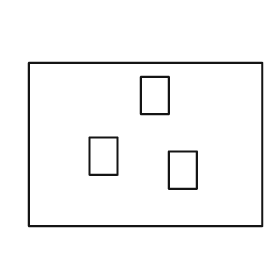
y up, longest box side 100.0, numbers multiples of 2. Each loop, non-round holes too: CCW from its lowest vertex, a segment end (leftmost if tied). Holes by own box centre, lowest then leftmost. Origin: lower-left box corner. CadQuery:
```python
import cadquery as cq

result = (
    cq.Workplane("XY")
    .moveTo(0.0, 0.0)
    .lineTo(100.0, 0.0)
    .lineTo(100.0, 70.0)
    .lineTo(0.0, 70.0)
    .close()
    .moveTo(60.0, 16.0)
    .lineTo(72.0, 16.0)
    .lineTo(72.0, 32.0)
    .lineTo(60.0, 32.0)
    .close()
    .moveTo(26.0, 22.0)
    .lineTo(38.0, 22.0)
    .lineTo(38.0, 38.0)
    .lineTo(26.0, 38.0)
    .close()
    .moveTo(48.0, 48.0)
    .lineTo(60.0, 48.0)
    .lineTo(60.0, 64.0)
    .lineTo(48.0, 64.0)
    .close()
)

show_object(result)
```